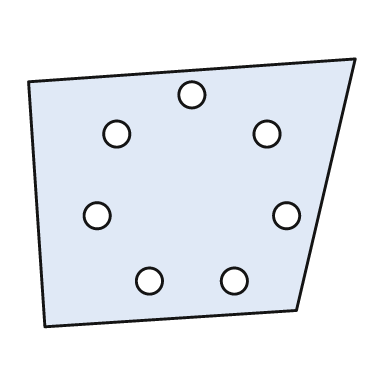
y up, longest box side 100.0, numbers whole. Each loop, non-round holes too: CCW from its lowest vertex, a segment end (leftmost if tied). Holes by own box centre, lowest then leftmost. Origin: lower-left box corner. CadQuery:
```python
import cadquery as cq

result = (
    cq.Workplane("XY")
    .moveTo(5.0, 0.0)
    .lineTo(82.0, 5.0)
    .lineTo(100.0, 82.0)
    .lineTo(0.0, 75.0)
    .close()
    .moveTo(37.0, 14.0)
    .circle(4.0)
    .moveTo(63.0, 14.0)
    .circle(4.0)
    .moveTo(21.0, 34.0)
    .circle(4.0)
    .moveTo(79.0, 34.0)
    .circle(4.0)
    .moveTo(27.0, 59.0)
    .circle(4.0)
    .moveTo(73.0, 59.0)
    .circle(4.0)
    .moveTo(50.0, 71.0)
    .circle(4.0)
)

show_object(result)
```